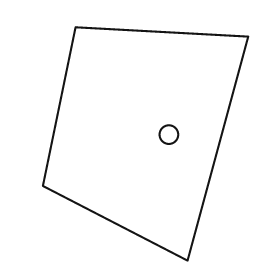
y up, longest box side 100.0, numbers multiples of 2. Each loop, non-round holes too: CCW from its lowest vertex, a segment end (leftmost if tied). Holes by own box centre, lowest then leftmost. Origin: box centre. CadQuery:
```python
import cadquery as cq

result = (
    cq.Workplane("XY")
    .moveTo(18.0, -50.0)
    .lineTo(44.0, 46.0)
    .lineTo(-30.0, 50.0)
    .lineTo(-44.0, -18.0)
    .close()
    .moveTo(10.0, 4.0)
    .circle(4.0)
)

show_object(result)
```